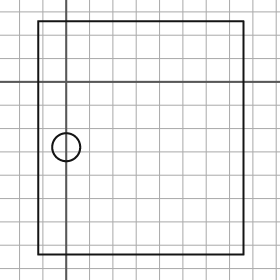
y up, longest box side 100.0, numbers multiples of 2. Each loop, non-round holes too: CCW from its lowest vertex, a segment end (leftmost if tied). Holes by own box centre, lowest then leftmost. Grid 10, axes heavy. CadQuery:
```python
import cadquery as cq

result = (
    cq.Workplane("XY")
    .moveTo(-12.0, -74.0)
    .lineTo(76.0, -74.0)
    .lineTo(76.0, 26.0)
    .lineTo(-12.0, 26.0)
    .close()
    .moveTo(0.0, -28.0)
    .circle(6.0)
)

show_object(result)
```